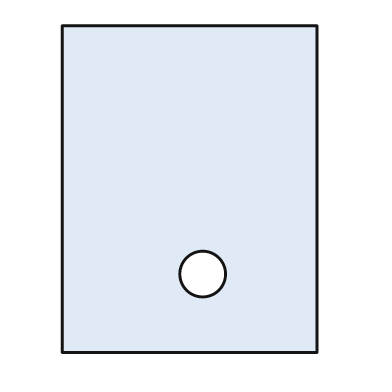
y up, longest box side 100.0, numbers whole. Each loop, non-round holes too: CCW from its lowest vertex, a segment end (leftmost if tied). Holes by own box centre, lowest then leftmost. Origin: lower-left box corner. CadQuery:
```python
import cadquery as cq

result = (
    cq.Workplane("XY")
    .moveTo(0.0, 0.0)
    .lineTo(78.0, 0.0)
    .lineTo(78.0, 100.0)
    .lineTo(0.0, 100.0)
    .close()
    .moveTo(43.0, 24.0)
    .circle(7.0)
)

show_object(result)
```